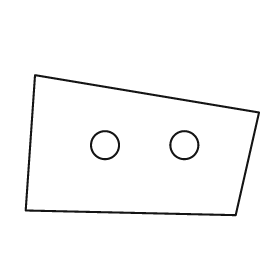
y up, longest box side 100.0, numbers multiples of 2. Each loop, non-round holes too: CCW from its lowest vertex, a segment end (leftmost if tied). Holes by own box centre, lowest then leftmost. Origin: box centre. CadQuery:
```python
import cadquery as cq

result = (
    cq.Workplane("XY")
    .moveTo(40.0, -30.0)
    .lineTo(50.0, 14.0)
    .lineTo(-46.0, 30.0)
    .lineTo(-50.0, -28.0)
    .close()
    .moveTo(-16.0, 0.0)
    .circle(6.0)
    .moveTo(18.0, 0.0)
    .circle(6.0)
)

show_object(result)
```